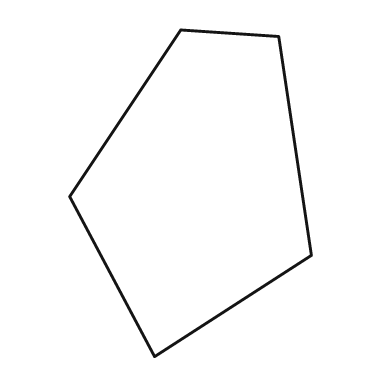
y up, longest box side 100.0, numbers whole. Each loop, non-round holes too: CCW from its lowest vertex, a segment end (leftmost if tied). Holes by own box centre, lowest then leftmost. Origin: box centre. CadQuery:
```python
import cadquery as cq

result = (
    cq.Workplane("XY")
    .moveTo(-11.0, -50.0)
    .lineTo(37.0, -19.0)
    .lineTo(27.0, 48.0)
    .lineTo(-3.0, 50.0)
    .lineTo(-37.0, -1.0)
    .close()
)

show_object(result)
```